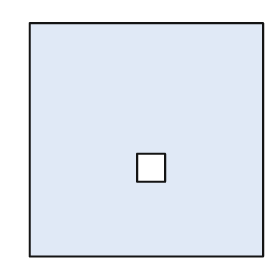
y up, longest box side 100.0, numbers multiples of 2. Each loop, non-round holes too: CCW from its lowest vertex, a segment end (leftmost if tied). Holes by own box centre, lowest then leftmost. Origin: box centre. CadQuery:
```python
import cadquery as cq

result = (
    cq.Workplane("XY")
    .moveTo(-50.0, -50.0)
    .lineTo(50.0, -50.0)
    .lineTo(50.0, 50.0)
    .lineTo(-50.0, 50.0)
    .close()
    .moveTo(-4.0, -18.0)
    .lineTo(8.0, -18.0)
    .lineTo(8.0, -6.0)
    .lineTo(-4.0, -6.0)
    .close()
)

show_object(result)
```